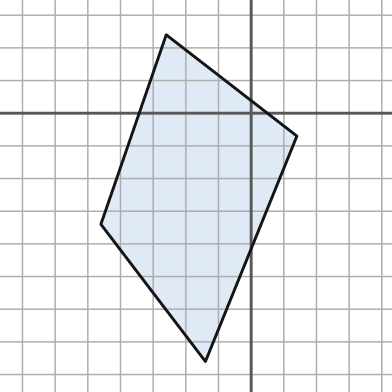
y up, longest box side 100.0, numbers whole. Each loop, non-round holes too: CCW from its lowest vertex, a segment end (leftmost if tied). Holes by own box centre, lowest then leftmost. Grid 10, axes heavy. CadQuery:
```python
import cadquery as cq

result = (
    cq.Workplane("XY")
    .moveTo(-14.0, -76.0)
    .lineTo(14.0, -7.0)
    .lineTo(-26.0, 24.0)
    .lineTo(-46.0, -34.0)
    .close()
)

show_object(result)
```